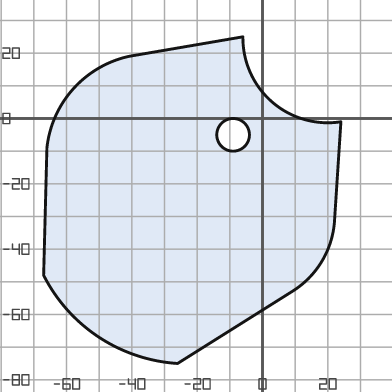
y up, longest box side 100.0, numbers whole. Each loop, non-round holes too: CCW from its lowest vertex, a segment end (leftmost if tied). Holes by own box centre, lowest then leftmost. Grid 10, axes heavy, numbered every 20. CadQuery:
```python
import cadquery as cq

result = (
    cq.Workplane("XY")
    .moveTo(-26.0, -75.0)
    .lineTo(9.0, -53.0)
    .threePointArc((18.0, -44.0), (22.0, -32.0))
    .lineTo(24.0, -1.0)
    .threePointArc((3.0, 5.0), (-6.0, 25.0))
    .lineTo(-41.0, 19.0)
    .threePointArc((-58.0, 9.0), (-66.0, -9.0))
    .lineTo(-67.0, -48.0)
    .threePointArc((-50.0, -67.0), (-26.0, -75.0))
    .close()
    .moveTo(-9.0, -5.0)
    .circle(5.0)
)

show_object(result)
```